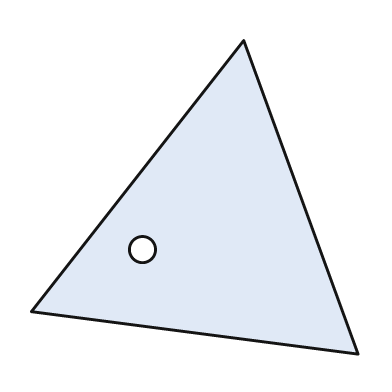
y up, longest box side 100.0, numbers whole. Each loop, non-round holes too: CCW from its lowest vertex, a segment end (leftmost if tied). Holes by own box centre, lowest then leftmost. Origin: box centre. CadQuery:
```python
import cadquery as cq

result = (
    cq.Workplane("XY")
    .moveTo(50.0, -48.0)
    .lineTo(15.0, 48.0)
    .lineTo(-50.0, -35.0)
    .close()
    .moveTo(-16.0, -16.0)
    .circle(4.0)
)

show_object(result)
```